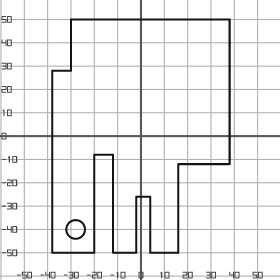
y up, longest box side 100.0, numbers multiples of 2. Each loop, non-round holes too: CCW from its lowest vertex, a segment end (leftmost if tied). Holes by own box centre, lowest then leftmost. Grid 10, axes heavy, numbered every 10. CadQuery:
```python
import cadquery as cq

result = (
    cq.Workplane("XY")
    .moveTo(-38.0, -50.0)
    .lineTo(-20.0, -50.0)
    .lineTo(-20.0, -8.0)
    .lineTo(-12.0, -8.0)
    .lineTo(-12.0, -50.0)
    .lineTo(-2.0, -50.0)
    .lineTo(-2.0, -26.0)
    .lineTo(4.0, -26.0)
    .lineTo(4.0, -50.0)
    .lineTo(16.0, -50.0)
    .lineTo(16.0, -12.0)
    .lineTo(38.0, -12.0)
    .lineTo(38.0, 50.0)
    .lineTo(-30.0, 50.0)
    .lineTo(-30.0, 28.0)
    .lineTo(-38.0, 28.0)
    .close()
    .moveTo(-28.0, -40.0)
    .circle(4.0)
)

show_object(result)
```